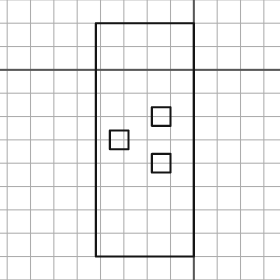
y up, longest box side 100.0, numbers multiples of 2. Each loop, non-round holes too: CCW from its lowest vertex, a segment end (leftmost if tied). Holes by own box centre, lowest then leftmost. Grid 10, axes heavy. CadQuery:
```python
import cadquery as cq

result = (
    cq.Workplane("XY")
    .moveTo(-42.0, -80.0)
    .lineTo(0.0, -80.0)
    .lineTo(0.0, 20.0)
    .lineTo(-42.0, 20.0)
    .close()
    .moveTo(-18.0, -44.0)
    .lineTo(-10.0, -44.0)
    .lineTo(-10.0, -36.0)
    .lineTo(-18.0, -36.0)
    .close()
    .moveTo(-36.0, -34.0)
    .lineTo(-28.0, -34.0)
    .lineTo(-28.0, -26.0)
    .lineTo(-36.0, -26.0)
    .close()
    .moveTo(-18.0, -24.0)
    .lineTo(-10.0, -24.0)
    .lineTo(-10.0, -16.0)
    .lineTo(-18.0, -16.0)
    .close()
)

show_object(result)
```